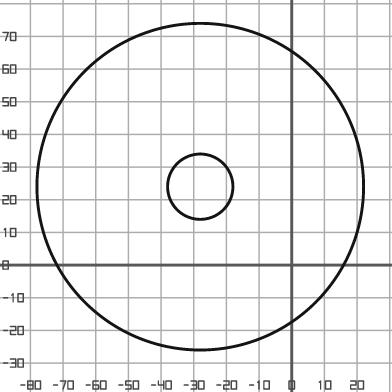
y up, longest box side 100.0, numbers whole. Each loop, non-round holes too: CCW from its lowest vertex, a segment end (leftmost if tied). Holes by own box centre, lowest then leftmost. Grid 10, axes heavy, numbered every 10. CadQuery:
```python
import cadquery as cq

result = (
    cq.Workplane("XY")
    .moveTo(-28.0, 24.0)
    .circle(50.0)
    .moveTo(-28.0, 24.0)
    .circle(10.0)
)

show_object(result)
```